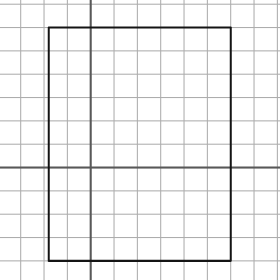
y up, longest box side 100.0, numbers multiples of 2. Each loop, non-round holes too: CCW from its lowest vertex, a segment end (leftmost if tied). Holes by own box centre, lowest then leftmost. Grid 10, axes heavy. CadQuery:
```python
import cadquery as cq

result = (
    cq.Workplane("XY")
    .moveTo(-18.0, -40.0)
    .lineTo(60.0, -40.0)
    .lineTo(60.0, 60.0)
    .lineTo(-18.0, 60.0)
    .close()
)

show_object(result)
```